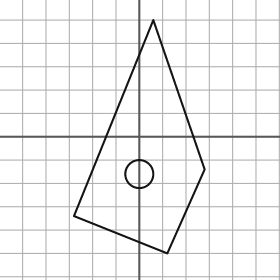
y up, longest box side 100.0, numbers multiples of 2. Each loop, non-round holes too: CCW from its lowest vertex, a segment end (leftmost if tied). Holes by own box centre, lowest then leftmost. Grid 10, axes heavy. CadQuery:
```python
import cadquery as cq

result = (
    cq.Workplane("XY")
    .moveTo(12.0, -50.0)
    .lineTo(28.0, -14.0)
    .lineTo(6.0, 50.0)
    .lineTo(-28.0, -34.0)
    .close()
    .moveTo(0.0, -16.0)
    .circle(6.0)
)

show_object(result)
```